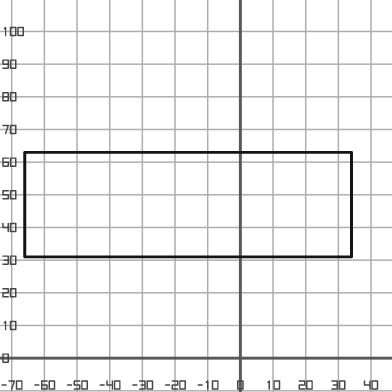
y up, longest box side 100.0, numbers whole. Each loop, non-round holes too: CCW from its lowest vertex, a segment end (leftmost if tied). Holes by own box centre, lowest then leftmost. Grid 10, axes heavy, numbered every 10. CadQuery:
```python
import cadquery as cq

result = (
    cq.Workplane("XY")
    .moveTo(-66.0, 31.0)
    .lineTo(34.0, 31.0)
    .lineTo(34.0, 63.0)
    .lineTo(-66.0, 63.0)
    .close()
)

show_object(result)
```